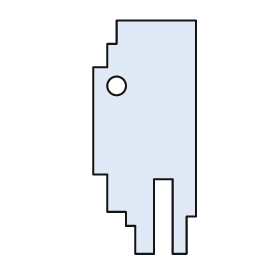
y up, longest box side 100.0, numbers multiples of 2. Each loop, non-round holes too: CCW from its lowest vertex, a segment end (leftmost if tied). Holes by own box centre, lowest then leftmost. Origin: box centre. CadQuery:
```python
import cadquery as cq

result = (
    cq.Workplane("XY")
    .moveTo(-4.0, -50.0)
    .lineTo(4.0, -50.0)
    .lineTo(4.0, -18.0)
    .lineTo(12.0, -18.0)
    .lineTo(12.0, -50.0)
    .lineTo(18.0, -50.0)
    .lineTo(18.0, -34.0)
    .lineTo(22.0, -34.0)
    .lineTo(22.0, 50.0)
    .lineTo(-12.0, 50.0)
    .lineTo(-12.0, 40.0)
    .lineTo(-16.0, 40.0)
    .lineTo(-16.0, 30.0)
    .lineTo(-22.0, 30.0)
    .lineTo(-22.0, -16.0)
    .lineTo(-16.0, -16.0)
    .lineTo(-16.0, -32.0)
    .lineTo(-8.0, -32.0)
    .lineTo(-8.0, -38.0)
    .lineTo(-4.0, -38.0)
    .close()
    .moveTo(-12.0, 22.0)
    .circle(4.0)
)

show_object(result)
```